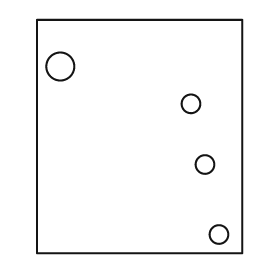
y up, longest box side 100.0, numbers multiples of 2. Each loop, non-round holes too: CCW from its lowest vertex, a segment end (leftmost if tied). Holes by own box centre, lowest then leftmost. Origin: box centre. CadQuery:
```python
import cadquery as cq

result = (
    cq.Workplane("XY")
    .moveTo(-44.0, -50.0)
    .lineTo(44.0, -50.0)
    .lineTo(44.0, 50.0)
    .lineTo(-44.0, 50.0)
    .close()
    .moveTo(34.0, -42.0)
    .circle(4.0)
    .moveTo(28.0, -12.0)
    .circle(4.0)
    .moveTo(22.0, 14.0)
    .circle(4.0)
    .moveTo(-34.0, 30.0)
    .circle(6.0)
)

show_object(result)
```